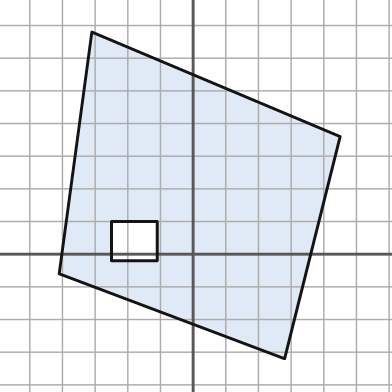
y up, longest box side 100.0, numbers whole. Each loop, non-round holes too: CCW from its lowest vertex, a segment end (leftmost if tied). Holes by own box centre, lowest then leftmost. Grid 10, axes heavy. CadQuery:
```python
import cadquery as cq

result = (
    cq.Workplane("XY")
    .moveTo(28.0, -32.0)
    .lineTo(45.0, 36.0)
    .lineTo(-31.0, 68.0)
    .lineTo(-41.0, -6.0)
    .close()
    .moveTo(-25.0, -2.0)
    .lineTo(-11.0, -2.0)
    .lineTo(-11.0, 10.0)
    .lineTo(-25.0, 10.0)
    .close()
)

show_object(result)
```